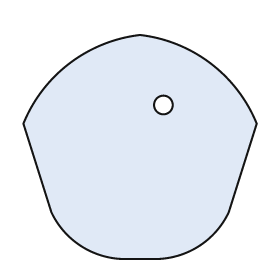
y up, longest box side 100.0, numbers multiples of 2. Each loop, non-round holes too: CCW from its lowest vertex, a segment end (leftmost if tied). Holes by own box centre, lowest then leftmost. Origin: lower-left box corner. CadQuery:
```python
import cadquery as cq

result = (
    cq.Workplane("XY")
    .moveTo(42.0, 0.0)
    .lineTo(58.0, 0.0)
    .threePointArc((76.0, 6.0), (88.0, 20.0))
    .lineTo(100.0, 58.0)
    .threePointArc((80.0, 84.0), (50.0, 96.0))
    .threePointArc((20.0, 84.0), (0.0, 58.0))
    .lineTo(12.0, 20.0)
    .threePointArc((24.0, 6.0), (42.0, 0.0))
    .close()
    .moveTo(60.0, 66.0)
    .circle(4.0)
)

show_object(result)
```